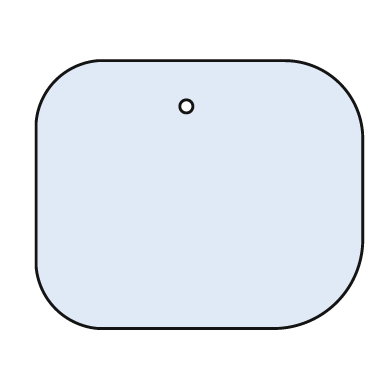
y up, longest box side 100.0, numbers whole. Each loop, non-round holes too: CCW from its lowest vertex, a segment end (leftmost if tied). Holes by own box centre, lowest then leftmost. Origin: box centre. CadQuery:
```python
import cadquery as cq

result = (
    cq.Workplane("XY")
    .moveTo(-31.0, -41.0)
    .lineTo(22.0, -41.0)
    .threePointArc((42.0, -33.0), (50.0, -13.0))
    .lineTo(50.0, 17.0)
    .threePointArc((43.0, 34.0), (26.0, 41.0))
    .lineTo(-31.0, 41.0)
    .threePointArc((-44.0, 35.0), (-50.0, 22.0))
    .lineTo(-50.0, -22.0)
    .threePointArc((-44.0, -35.0), (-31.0, -41.0))
    .close()
    .moveTo(-4.0, 27.0)
    .circle(2.0)
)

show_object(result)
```